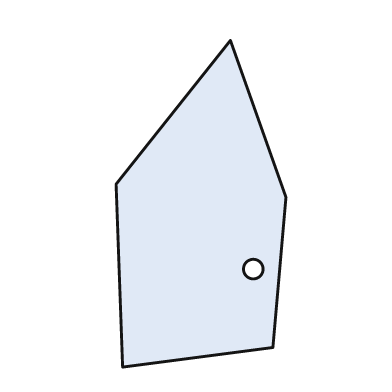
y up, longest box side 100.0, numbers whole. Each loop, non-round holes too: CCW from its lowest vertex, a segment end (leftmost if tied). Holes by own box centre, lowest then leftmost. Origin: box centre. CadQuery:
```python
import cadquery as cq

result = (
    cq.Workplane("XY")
    .moveTo(-24.0, -50.0)
    .lineTo(22.0, -44.0)
    .lineTo(26.0, 2.0)
    .lineTo(9.0, 50.0)
    .lineTo(-26.0, 6.0)
    .close()
    .moveTo(16.0, -20.0)
    .circle(3.0)
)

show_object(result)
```